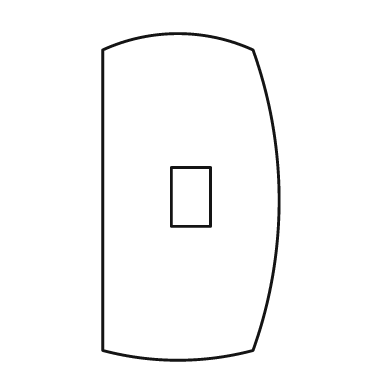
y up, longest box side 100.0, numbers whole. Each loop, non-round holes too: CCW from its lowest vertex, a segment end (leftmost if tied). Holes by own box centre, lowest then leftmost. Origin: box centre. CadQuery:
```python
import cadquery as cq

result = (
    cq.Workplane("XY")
    .moveTo(-27.0, -47.0)
    .threePointArc((-4.0, -50.0), (19.0, -47.0))
    .threePointArc((27.0, -1.0), (19.0, 45.0))
    .threePointArc((-4.0, 50.0), (-27.0, 45.0))
    .close()
    .moveTo(-6.0, -9.0)
    .lineTo(6.0, -9.0)
    .lineTo(6.0, 9.0)
    .lineTo(-6.0, 9.0)
    .close()
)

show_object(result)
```